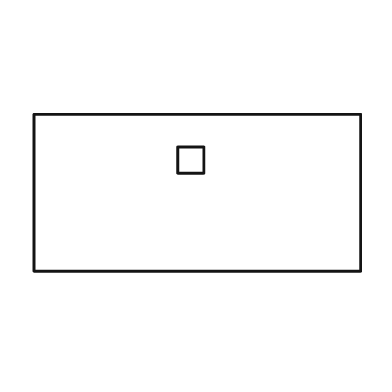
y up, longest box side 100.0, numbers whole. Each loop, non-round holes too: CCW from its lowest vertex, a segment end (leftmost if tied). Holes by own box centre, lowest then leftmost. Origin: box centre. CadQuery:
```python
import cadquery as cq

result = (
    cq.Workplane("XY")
    .moveTo(-50.0, -24.0)
    .lineTo(50.0, -24.0)
    .lineTo(50.0, 24.0)
    .lineTo(-50.0, 24.0)
    .close()
    .moveTo(-6.0, 6.0)
    .lineTo(2.0, 6.0)
    .lineTo(2.0, 14.0)
    .lineTo(-6.0, 14.0)
    .close()
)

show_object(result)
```